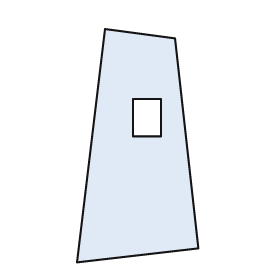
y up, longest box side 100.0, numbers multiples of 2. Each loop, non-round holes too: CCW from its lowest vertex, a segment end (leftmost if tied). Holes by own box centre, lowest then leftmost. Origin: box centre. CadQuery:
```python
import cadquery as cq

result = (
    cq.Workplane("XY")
    .moveTo(-26.0, -50.0)
    .lineTo(26.0, -44.0)
    .lineTo(16.0, 46.0)
    .lineTo(-14.0, 50.0)
    .close()
    .moveTo(-2.0, 4.0)
    .lineTo(10.0, 4.0)
    .lineTo(10.0, 20.0)
    .lineTo(-2.0, 20.0)
    .close()
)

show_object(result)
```